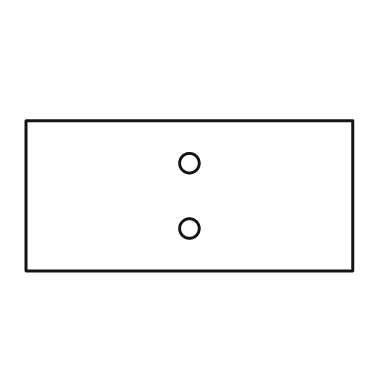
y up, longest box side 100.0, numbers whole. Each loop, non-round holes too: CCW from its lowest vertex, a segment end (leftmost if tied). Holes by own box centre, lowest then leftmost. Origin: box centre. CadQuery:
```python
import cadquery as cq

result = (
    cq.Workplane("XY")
    .moveTo(-50.0, -23.0)
    .lineTo(50.0, -23.0)
    .lineTo(50.0, 23.0)
    .lineTo(-50.0, 23.0)
    .close()
    .moveTo(0.0, -10.0)
    .circle(3.0)
    .moveTo(0.0, 10.0)
    .circle(3.0)
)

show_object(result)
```